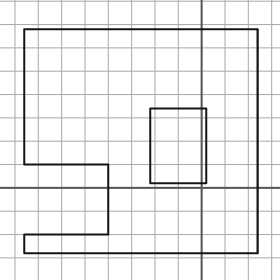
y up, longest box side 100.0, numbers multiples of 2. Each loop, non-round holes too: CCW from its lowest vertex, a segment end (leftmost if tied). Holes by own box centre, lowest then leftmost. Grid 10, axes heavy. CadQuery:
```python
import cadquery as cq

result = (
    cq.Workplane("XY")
    .moveTo(-76.0, -28.0)
    .lineTo(24.0, -28.0)
    .lineTo(24.0, 68.0)
    .lineTo(-76.0, 68.0)
    .lineTo(-76.0, 10.0)
    .lineTo(-40.0, 10.0)
    .lineTo(-40.0, -20.0)
    .lineTo(-76.0, -20.0)
    .close()
    .moveTo(-22.0, 2.0)
    .lineTo(2.0, 2.0)
    .lineTo(2.0, 34.0)
    .lineTo(-22.0, 34.0)
    .close()
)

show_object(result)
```